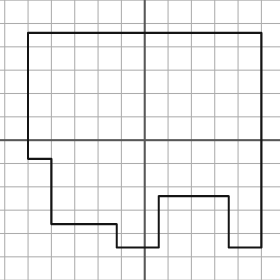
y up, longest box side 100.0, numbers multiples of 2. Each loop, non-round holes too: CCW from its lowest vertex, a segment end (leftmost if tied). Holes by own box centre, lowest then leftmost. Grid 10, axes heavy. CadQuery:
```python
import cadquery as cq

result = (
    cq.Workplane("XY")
    .moveTo(-12.0, -46.0)
    .lineTo(6.0, -46.0)
    .lineTo(6.0, -24.0)
    .lineTo(36.0, -24.0)
    .lineTo(36.0, -46.0)
    .lineTo(50.0, -46.0)
    .lineTo(50.0, 46.0)
    .lineTo(-50.0, 46.0)
    .lineTo(-50.0, -8.0)
    .lineTo(-40.0, -8.0)
    .lineTo(-40.0, -36.0)
    .lineTo(-12.0, -36.0)
    .close()
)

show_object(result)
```